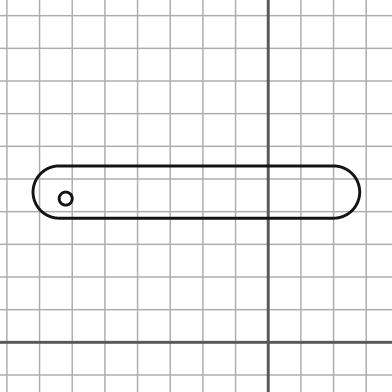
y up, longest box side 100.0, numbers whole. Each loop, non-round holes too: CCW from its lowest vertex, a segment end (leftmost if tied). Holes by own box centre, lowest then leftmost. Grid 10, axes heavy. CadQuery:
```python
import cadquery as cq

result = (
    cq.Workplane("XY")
    .moveTo(-64.0, 38.0)
    .lineTo(20.0, 38.0)
    .threePointArc((28.0, 46.0), (20.0, 54.0))
    .lineTo(-64.0, 54.0)
    .threePointArc((-72.0, 46.0), (-64.0, 38.0))
    .close()
    .moveTo(-62.0, 44.0)
    .circle(2.0)
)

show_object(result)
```